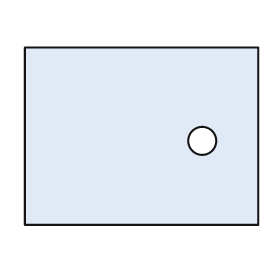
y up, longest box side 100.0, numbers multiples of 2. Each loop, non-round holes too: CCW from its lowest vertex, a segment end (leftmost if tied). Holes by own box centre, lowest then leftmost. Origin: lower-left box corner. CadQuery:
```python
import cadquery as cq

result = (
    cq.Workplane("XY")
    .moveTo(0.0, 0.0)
    .lineTo(100.0, 0.0)
    .lineTo(100.0, 76.0)
    .lineTo(0.0, 76.0)
    .close()
    .moveTo(76.0, 36.0)
    .circle(6.0)
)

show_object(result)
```